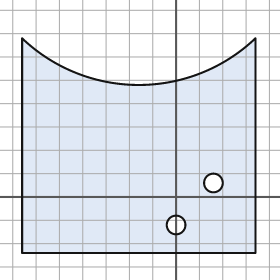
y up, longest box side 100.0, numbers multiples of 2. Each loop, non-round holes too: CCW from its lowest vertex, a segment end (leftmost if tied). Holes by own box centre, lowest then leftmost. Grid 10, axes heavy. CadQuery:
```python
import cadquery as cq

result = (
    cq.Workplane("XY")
    .moveTo(-66.0, -24.0)
    .lineTo(34.0, -24.0)
    .lineTo(34.0, 68.0)
    .threePointArc((-16.0, 48.0), (-66.0, 68.0))
    .close()
    .moveTo(0.0, -12.0)
    .circle(4.0)
    .moveTo(16.0, 6.0)
    .circle(4.0)
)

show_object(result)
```